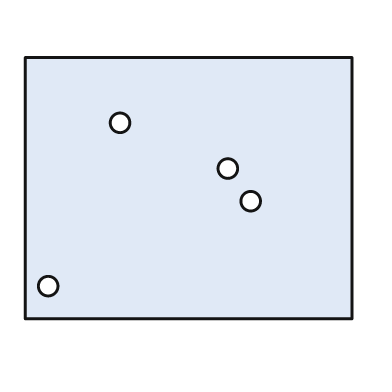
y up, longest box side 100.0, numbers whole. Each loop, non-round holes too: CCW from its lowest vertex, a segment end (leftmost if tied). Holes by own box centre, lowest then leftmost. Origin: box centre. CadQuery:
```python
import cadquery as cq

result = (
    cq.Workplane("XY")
    .moveTo(-50.0, -40.0)
    .lineTo(50.0, -40.0)
    .lineTo(50.0, 40.0)
    .lineTo(-50.0, 40.0)
    .close()
    .moveTo(-43.0, -30.0)
    .circle(3.0)
    .moveTo(19.0, -4.0)
    .circle(3.0)
    .moveTo(12.0, 6.0)
    .circle(3.0)
    .moveTo(-21.0, 20.0)
    .circle(3.0)
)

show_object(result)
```